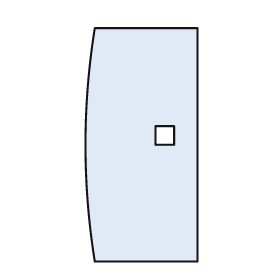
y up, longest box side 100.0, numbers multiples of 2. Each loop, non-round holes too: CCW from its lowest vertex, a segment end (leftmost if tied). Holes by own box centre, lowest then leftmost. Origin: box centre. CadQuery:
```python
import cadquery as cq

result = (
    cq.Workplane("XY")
    .moveTo(-20.0, -50.0)
    .lineTo(24.0, -50.0)
    .lineTo(24.0, 50.0)
    .lineTo(-20.0, 50.0)
    .threePointArc((-24.0, 0.0), (-20.0, -50.0))
    .close()
    .moveTo(6.0, 0.0)
    .lineTo(14.0, 0.0)
    .lineTo(14.0, 8.0)
    .lineTo(6.0, 8.0)
    .close()
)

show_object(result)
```